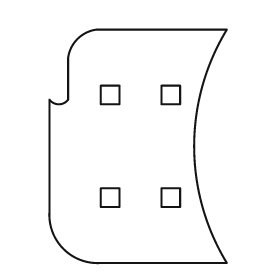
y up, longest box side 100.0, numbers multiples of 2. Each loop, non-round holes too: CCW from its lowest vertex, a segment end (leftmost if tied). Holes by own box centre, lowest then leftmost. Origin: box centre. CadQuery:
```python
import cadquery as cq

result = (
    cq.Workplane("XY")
    .moveTo(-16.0, -50.0)
    .lineTo(38.0, -50.0)
    .threePointArc((24.0, 0.0), (38.0, 50.0))
    .lineTo(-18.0, 50.0)
    .threePointArc((-26.0, 46.0), (-30.0, 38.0))
    .lineTo(-30.0, 20.0)
    .threePointArc((-34.0, 18.0), (-38.0, 20.0))
    .lineTo(-38.0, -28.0)
    .threePointArc((-32.0, -44.0), (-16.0, -50.0))
    .close()
    .moveTo(-16.0, -26.0)
    .lineTo(-8.0, -26.0)
    .lineTo(-8.0, -18.0)
    .lineTo(-16.0, -18.0)
    .close()
    .moveTo(10.0, -26.0)
    .lineTo(18.0, -26.0)
    .lineTo(18.0, -18.0)
    .lineTo(10.0, -18.0)
    .close()
    .moveTo(-16.0, 18.0)
    .lineTo(-8.0, 18.0)
    .lineTo(-8.0, 26.0)
    .lineTo(-16.0, 26.0)
    .close()
    .moveTo(10.0, 18.0)
    .lineTo(18.0, 18.0)
    .lineTo(18.0, 26.0)
    .lineTo(10.0, 26.0)
    .close()
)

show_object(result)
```